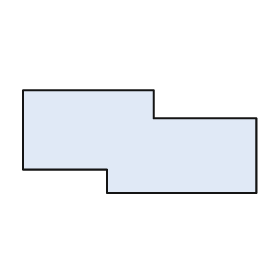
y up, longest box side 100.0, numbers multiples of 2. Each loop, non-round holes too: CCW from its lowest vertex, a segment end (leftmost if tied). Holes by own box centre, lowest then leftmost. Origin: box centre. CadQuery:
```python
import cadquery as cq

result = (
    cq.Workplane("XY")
    .moveTo(-14.0, -22.0)
    .lineTo(50.0, -22.0)
    .lineTo(50.0, 10.0)
    .lineTo(6.0, 10.0)
    .lineTo(6.0, 22.0)
    .lineTo(-50.0, 22.0)
    .lineTo(-50.0, -12.0)
    .lineTo(-14.0, -12.0)
    .close()
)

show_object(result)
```